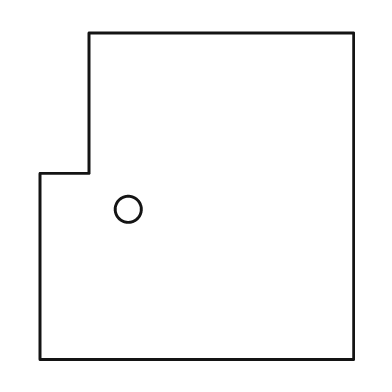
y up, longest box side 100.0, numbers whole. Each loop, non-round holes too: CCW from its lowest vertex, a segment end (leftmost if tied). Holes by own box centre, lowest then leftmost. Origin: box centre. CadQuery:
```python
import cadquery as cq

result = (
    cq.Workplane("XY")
    .moveTo(-48.0, -50.0)
    .lineTo(48.0, -50.0)
    .lineTo(48.0, 50.0)
    .lineTo(-33.0, 50.0)
    .lineTo(-33.0, 7.0)
    .lineTo(-48.0, 7.0)
    .close()
    .moveTo(-21.0, -4.0)
    .circle(4.0)
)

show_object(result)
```